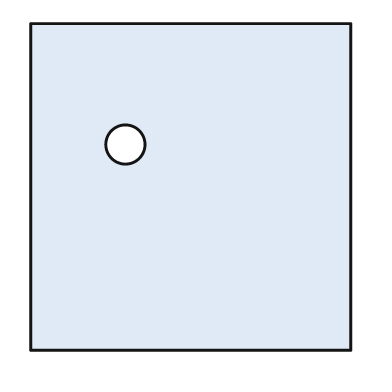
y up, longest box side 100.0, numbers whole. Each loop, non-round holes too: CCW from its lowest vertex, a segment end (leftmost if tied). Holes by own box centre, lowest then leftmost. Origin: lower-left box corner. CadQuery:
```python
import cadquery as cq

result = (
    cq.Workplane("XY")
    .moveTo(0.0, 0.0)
    .lineTo(98.0, 0.0)
    .lineTo(98.0, 100.0)
    .lineTo(0.0, 100.0)
    .close()
    .moveTo(29.0, 63.0)
    .circle(6.0)
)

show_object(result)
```